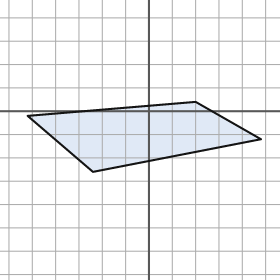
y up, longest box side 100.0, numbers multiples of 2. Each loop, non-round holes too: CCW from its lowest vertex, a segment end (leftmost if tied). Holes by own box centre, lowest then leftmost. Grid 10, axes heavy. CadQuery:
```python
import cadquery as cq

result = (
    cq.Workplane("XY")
    .moveTo(-24.0, -26.0)
    .lineTo(48.0, -12.0)
    .lineTo(20.0, 4.0)
    .lineTo(-52.0, -2.0)
    .close()
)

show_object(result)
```